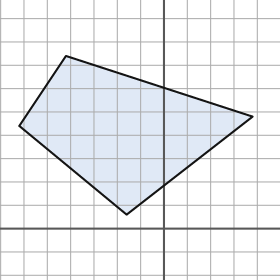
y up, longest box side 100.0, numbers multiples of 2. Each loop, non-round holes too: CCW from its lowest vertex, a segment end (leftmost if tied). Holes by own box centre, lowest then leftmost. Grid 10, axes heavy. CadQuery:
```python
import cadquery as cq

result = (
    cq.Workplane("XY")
    .moveTo(-16.0, 6.0)
    .lineTo(38.0, 48.0)
    .lineTo(-42.0, 74.0)
    .lineTo(-62.0, 44.0)
    .close()
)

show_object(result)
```